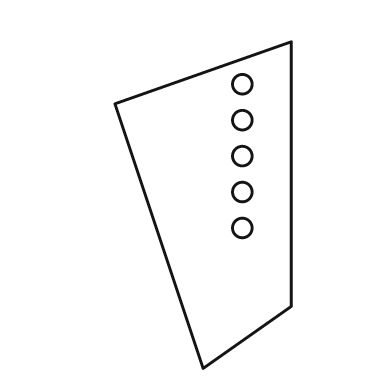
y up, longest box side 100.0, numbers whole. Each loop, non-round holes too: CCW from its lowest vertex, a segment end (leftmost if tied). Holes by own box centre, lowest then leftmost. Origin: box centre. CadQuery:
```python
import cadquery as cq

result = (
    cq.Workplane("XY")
    .moveTo(0.0, -50.0)
    .lineTo(27.0, -31.0)
    .lineTo(27.0, 50.0)
    .lineTo(-27.0, 31.0)
    .close()
    .moveTo(12.0, -7.0)
    .circle(3.0)
    .moveTo(12.0, 4.0)
    .circle(3.0)
    .moveTo(12.0, 15.0)
    .circle(3.0)
    .moveTo(12.0, 26.0)
    .circle(3.0)
    .moveTo(12.0, 37.0)
    .circle(3.0)
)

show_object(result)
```